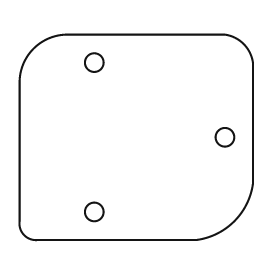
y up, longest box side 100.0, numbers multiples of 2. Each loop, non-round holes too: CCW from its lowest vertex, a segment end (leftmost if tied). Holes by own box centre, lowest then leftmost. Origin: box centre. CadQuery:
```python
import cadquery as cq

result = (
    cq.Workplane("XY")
    .moveTo(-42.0, -44.0)
    .lineTo(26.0, -44.0)
    .threePointArc((42.0, -36.0), (50.0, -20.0))
    .lineTo(50.0, 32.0)
    .threePointArc((46.0, 40.0), (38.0, 44.0))
    .lineTo(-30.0, 44.0)
    .threePointArc((-44.0, 38.0), (-50.0, 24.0))
    .lineTo(-50.0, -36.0)
    .threePointArc((-48.0, -42.0), (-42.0, -44.0))
    .close()
    .moveTo(-18.0, -32.0)
    .circle(4.0)
    .moveTo(38.0, 0.0)
    .circle(4.0)
    .moveTo(-18.0, 32.0)
    .circle(4.0)
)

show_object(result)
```